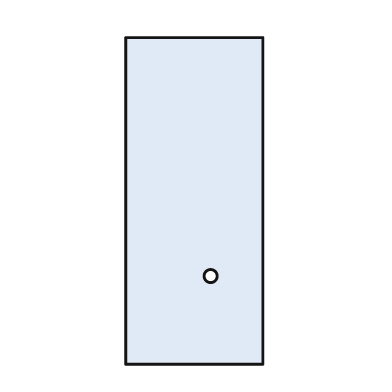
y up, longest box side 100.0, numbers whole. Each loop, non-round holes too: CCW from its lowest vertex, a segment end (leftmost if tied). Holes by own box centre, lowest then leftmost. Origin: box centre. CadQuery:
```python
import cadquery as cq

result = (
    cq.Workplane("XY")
    .moveTo(-21.0, -50.0)
    .lineTo(21.0, -50.0)
    .lineTo(21.0, 50.0)
    .lineTo(-21.0, 50.0)
    .close()
    .moveTo(5.0, -23.0)
    .circle(2.0)
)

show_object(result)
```